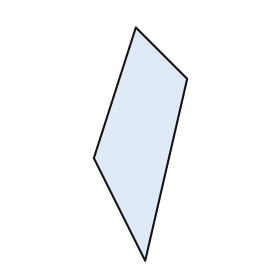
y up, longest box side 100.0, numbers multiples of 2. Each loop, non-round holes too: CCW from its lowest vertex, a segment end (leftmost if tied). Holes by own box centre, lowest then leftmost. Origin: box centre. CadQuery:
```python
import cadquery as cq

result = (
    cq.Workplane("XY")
    .moveTo(2.0, -50.0)
    .lineTo(20.0, 28.0)
    .lineTo(-2.0, 50.0)
    .lineTo(-20.0, -6.0)
    .close()
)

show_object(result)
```